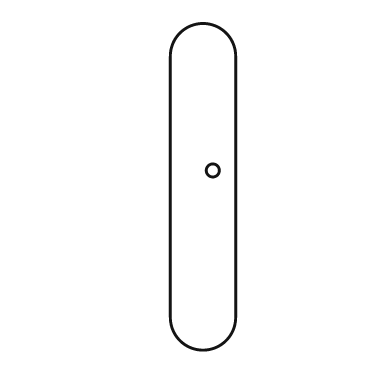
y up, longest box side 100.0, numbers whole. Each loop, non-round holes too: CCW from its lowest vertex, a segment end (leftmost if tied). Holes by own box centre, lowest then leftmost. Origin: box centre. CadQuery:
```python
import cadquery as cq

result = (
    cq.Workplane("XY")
    .moveTo(-10.0, -40.0)
    .threePointArc((0.0, -50.0), (10.0, -40.0))
    .lineTo(10.0, 40.0)
    .threePointArc((0.0, 50.0), (-10.0, 40.0))
    .close()
    .moveTo(3.0, 5.0)
    .circle(2.0)
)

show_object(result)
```